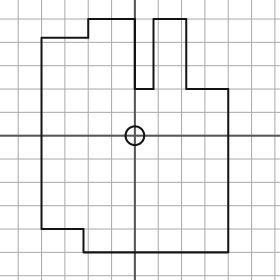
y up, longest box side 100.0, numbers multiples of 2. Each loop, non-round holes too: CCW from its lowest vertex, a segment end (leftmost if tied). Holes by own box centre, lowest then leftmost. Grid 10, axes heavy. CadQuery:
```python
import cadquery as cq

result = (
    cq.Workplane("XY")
    .moveTo(-22.0, -50.0)
    .lineTo(40.0, -50.0)
    .lineTo(40.0, 20.0)
    .lineTo(22.0, 20.0)
    .lineTo(22.0, 50.0)
    .lineTo(8.0, 50.0)
    .lineTo(8.0, 20.0)
    .lineTo(0.0, 20.0)
    .lineTo(0.0, 50.0)
    .lineTo(-20.0, 50.0)
    .lineTo(-20.0, 42.0)
    .lineTo(-40.0, 42.0)
    .lineTo(-40.0, -40.0)
    .lineTo(-22.0, -40.0)
    .close()
    .moveTo(0.0, 0.0)
    .circle(4.0)
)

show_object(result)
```